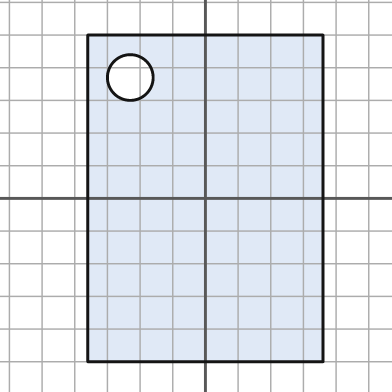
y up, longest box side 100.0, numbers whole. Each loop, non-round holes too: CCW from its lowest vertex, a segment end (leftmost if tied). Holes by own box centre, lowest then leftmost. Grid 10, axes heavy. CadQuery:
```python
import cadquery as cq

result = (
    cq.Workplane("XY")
    .moveTo(-36.0, -50.0)
    .lineTo(36.0, -50.0)
    .lineTo(36.0, 50.0)
    .lineTo(-36.0, 50.0)
    .close()
    .moveTo(-23.0, 37.0)
    .circle(7.0)
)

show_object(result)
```